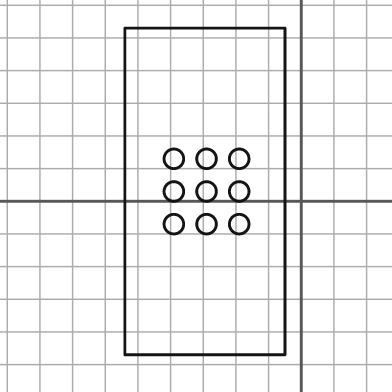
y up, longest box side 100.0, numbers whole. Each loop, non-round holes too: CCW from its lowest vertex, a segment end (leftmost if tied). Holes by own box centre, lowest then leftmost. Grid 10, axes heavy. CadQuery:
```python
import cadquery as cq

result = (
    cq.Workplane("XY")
    .moveTo(-54.0, -47.0)
    .lineTo(-5.0, -47.0)
    .lineTo(-5.0, 53.0)
    .lineTo(-54.0, 53.0)
    .close()
    .moveTo(-39.0, -7.0)
    .circle(3.0)
    .moveTo(-29.0, -7.0)
    .circle(3.0)
    .moveTo(-19.0, -7.0)
    .circle(3.0)
    .moveTo(-39.0, 3.0)
    .circle(3.0)
    .moveTo(-29.0, 3.0)
    .circle(3.0)
    .moveTo(-19.0, 3.0)
    .circle(3.0)
    .moveTo(-39.0, 13.0)
    .circle(3.0)
    .moveTo(-29.0, 13.0)
    .circle(3.0)
    .moveTo(-19.0, 13.0)
    .circle(3.0)
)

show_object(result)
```